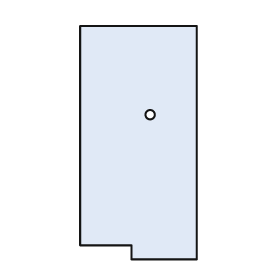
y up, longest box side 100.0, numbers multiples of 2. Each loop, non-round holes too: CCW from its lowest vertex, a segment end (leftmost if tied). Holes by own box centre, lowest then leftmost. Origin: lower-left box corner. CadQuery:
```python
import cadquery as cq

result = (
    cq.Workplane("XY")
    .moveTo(22.0, 0.0)
    .lineTo(50.0, 0.0)
    .lineTo(50.0, 100.0)
    .lineTo(0.0, 100.0)
    .lineTo(0.0, 6.0)
    .lineTo(22.0, 6.0)
    .close()
    .moveTo(30.0, 62.0)
    .circle(2.0)
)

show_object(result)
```